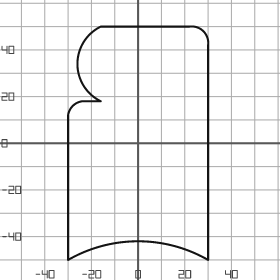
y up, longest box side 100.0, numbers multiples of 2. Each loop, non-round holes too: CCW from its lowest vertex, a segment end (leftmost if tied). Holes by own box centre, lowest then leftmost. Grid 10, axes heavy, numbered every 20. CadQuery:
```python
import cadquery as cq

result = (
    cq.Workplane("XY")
    .moveTo(-30.0, -50.0)
    .threePointArc((0.0, -42.0), (30.0, -50.0))
    .lineTo(30.0, 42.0)
    .threePointArc((28.0, 48.0), (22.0, 50.0))
    .lineTo(-16.0, 50.0)
    .threePointArc((-26.0, 34.0), (-16.0, 18.0))
    .lineTo(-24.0, 18.0)
    .threePointArc((-28.0, 16.0), (-30.0, 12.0))
    .close()
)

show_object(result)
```